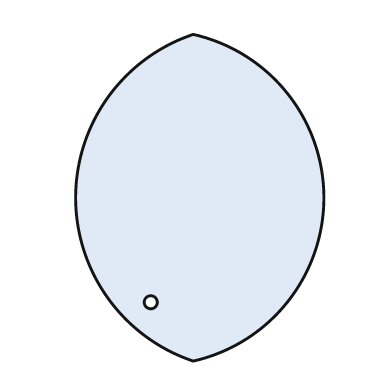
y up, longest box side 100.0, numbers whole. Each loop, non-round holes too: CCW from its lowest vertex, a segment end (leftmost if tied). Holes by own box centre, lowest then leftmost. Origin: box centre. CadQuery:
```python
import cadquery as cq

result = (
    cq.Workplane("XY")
    .moveTo(-2.0, -50.0)
    .threePointArc((38.0, 0.0), (-2.0, 50.0))
    .threePointArc((-38.0, 0.0), (-2.0, -50.0))
    .close()
    .moveTo(-15.0, -32.0)
    .circle(2.0)
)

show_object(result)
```